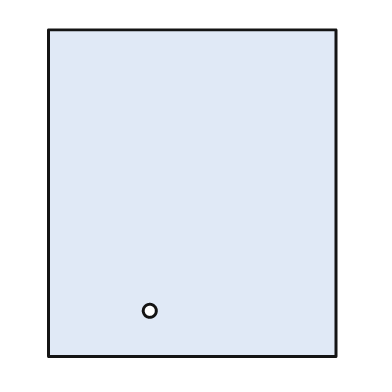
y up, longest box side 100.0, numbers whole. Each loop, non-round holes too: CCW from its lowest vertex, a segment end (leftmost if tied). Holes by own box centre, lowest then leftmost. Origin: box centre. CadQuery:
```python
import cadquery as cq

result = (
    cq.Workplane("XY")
    .moveTo(-44.0, -50.0)
    .lineTo(44.0, -50.0)
    .lineTo(44.0, 50.0)
    .lineTo(-44.0, 50.0)
    .close()
    .moveTo(-13.0, -36.0)
    .circle(2.0)
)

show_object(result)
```